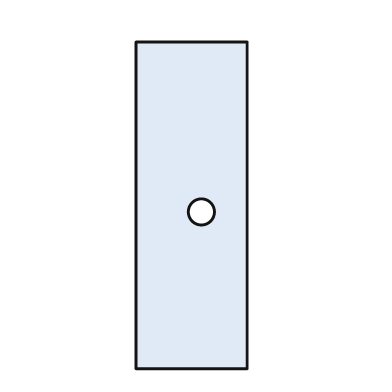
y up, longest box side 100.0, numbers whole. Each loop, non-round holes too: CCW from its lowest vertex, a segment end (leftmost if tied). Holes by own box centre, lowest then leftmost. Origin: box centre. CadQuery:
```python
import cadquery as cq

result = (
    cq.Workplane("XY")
    .moveTo(-17.0, -50.0)
    .lineTo(17.0, -50.0)
    .lineTo(17.0, 50.0)
    .lineTo(-17.0, 50.0)
    .close()
    .moveTo(3.0, -2.0)
    .circle(4.0)
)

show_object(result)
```